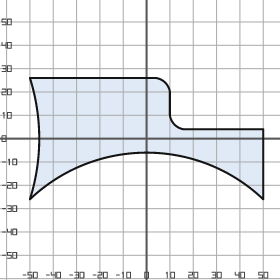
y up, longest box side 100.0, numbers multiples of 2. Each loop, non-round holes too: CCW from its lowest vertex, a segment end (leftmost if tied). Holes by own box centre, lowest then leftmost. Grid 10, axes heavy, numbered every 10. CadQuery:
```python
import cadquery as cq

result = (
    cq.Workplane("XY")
    .moveTo(-50.0, -26.0)
    .threePointArc((0.0, -6.0), (50.0, -26.0))
    .lineTo(50.0, 4.0)
    .lineTo(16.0, 4.0)
    .threePointArc((12.0, 6.0), (10.0, 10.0))
    .lineTo(10.0, 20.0)
    .threePointArc((8.0, 24.0), (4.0, 26.0))
    .lineTo(-50.0, 26.0)
    .threePointArc((-46.0, 0.0), (-50.0, -26.0))
    .close()
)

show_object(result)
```